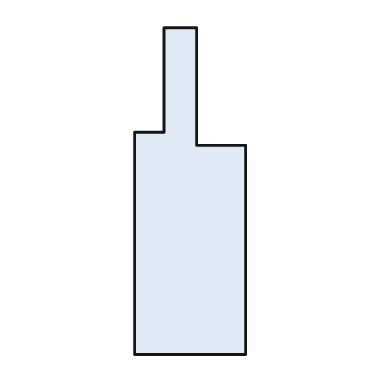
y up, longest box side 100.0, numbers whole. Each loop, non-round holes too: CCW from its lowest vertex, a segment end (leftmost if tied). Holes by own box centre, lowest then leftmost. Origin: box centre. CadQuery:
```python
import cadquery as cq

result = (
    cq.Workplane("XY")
    .moveTo(-17.0, -50.0)
    .lineTo(17.0, -50.0)
    .lineTo(17.0, 14.0)
    .lineTo(2.0, 14.0)
    .lineTo(2.0, 50.0)
    .lineTo(-8.0, 50.0)
    .lineTo(-8.0, 18.0)
    .lineTo(-17.0, 18.0)
    .close()
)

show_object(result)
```